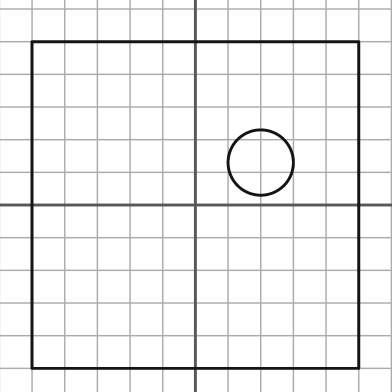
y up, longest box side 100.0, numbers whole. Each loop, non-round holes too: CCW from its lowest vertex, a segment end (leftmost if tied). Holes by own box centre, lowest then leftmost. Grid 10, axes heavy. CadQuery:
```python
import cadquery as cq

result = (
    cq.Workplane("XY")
    .moveTo(-50.0, -50.0)
    .lineTo(50.0, -50.0)
    .lineTo(50.0, 50.0)
    .lineTo(-50.0, 50.0)
    .close()
    .moveTo(20.0, 13.0)
    .circle(10.0)
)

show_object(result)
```